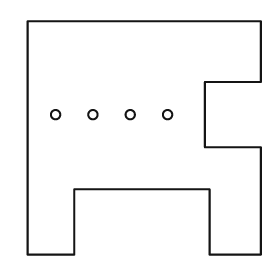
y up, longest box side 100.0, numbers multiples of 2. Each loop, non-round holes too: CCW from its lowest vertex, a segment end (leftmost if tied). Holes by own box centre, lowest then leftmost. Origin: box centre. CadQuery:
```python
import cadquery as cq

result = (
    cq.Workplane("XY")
    .moveTo(-50.0, -50.0)
    .lineTo(-30.0, -50.0)
    .lineTo(-30.0, -22.0)
    .lineTo(28.0, -22.0)
    .lineTo(28.0, -50.0)
    .lineTo(50.0, -50.0)
    .lineTo(50.0, -4.0)
    .lineTo(26.0, -4.0)
    .lineTo(26.0, 24.0)
    .lineTo(50.0, 24.0)
    .lineTo(50.0, 50.0)
    .lineTo(-50.0, 50.0)
    .close()
    .moveTo(-38.0, 10.0)
    .circle(2.0)
    .moveTo(-22.0, 10.0)
    .circle(2.0)
    .moveTo(-6.0, 10.0)
    .circle(2.0)
    .moveTo(10.0, 10.0)
    .circle(2.0)
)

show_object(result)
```